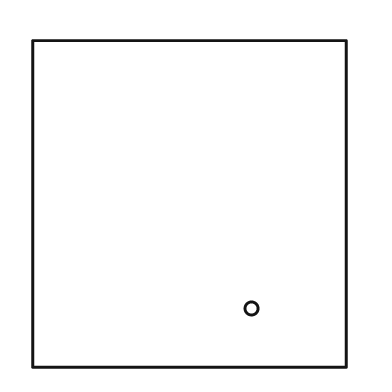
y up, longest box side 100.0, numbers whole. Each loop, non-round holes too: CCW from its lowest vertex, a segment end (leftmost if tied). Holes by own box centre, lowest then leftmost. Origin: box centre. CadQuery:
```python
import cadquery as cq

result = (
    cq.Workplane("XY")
    .moveTo(-48.0, -50.0)
    .lineTo(48.0, -50.0)
    .lineTo(48.0, 50.0)
    .lineTo(-48.0, 50.0)
    .close()
    .moveTo(19.0, -32.0)
    .circle(2.0)
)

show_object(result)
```